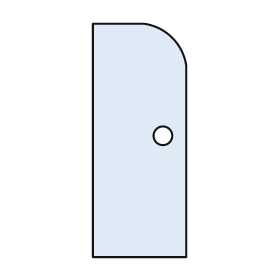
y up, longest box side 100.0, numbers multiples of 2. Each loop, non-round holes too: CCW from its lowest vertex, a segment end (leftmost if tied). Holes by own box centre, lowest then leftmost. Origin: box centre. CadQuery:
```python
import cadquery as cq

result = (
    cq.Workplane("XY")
    .moveTo(-20.0, -50.0)
    .lineTo(20.0, -50.0)
    .lineTo(20.0, 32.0)
    .threePointArc((14.0, 44.0), (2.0, 50.0))
    .lineTo(-20.0, 50.0)
    .close()
    .moveTo(10.0, 2.0)
    .circle(4.0)
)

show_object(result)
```